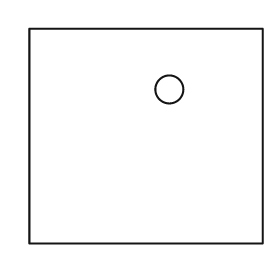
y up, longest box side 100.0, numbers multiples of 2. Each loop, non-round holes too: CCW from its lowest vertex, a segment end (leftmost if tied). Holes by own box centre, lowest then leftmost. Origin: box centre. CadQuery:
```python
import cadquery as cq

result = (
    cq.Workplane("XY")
    .moveTo(-50.0, -46.0)
    .lineTo(50.0, -46.0)
    .lineTo(50.0, 46.0)
    .lineTo(-50.0, 46.0)
    .close()
    .moveTo(10.0, 20.0)
    .circle(6.0)
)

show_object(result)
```